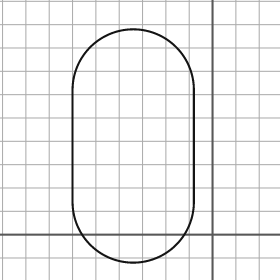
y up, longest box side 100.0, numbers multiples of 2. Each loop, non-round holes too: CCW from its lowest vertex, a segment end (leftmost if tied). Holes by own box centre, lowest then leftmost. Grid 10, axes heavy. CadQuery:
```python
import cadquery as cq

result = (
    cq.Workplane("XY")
    .moveTo(-60.0, 14.0)
    .threePointArc((-34.0, -12.0), (-8.0, 14.0))
    .lineTo(-8.0, 62.0)
    .threePointArc((-34.0, 88.0), (-60.0, 62.0))
    .close()
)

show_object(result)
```